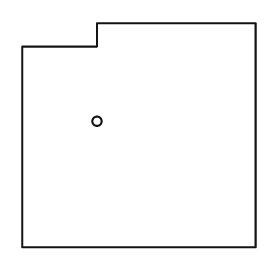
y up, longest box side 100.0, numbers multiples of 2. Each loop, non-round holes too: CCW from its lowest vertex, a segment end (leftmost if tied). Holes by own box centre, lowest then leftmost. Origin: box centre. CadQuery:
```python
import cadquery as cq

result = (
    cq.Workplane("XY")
    .moveTo(-50.0, -48.0)
    .lineTo(50.0, -48.0)
    .lineTo(50.0, 48.0)
    .lineTo(-18.0, 48.0)
    .lineTo(-18.0, 38.0)
    .lineTo(-50.0, 38.0)
    .close()
    .moveTo(-18.0, 6.0)
    .circle(2.0)
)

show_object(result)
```